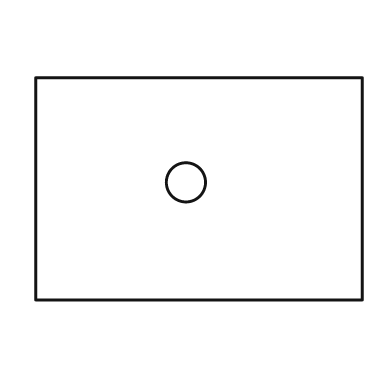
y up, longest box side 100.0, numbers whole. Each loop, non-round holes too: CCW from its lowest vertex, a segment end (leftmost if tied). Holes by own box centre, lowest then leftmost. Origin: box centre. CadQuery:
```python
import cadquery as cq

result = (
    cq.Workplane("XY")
    .moveTo(-50.0, -34.0)
    .lineTo(50.0, -34.0)
    .lineTo(50.0, 34.0)
    .lineTo(-50.0, 34.0)
    .close()
    .moveTo(-4.0, 2.0)
    .circle(6.0)
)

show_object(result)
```